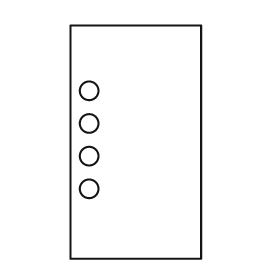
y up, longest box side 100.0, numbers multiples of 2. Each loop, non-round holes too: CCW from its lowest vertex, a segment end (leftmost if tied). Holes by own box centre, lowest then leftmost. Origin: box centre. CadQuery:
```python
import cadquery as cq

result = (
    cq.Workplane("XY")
    .moveTo(-28.0, -50.0)
    .lineTo(28.0, -50.0)
    .lineTo(28.0, 50.0)
    .lineTo(-28.0, 50.0)
    .close()
    .moveTo(-20.0, -20.0)
    .circle(4.0)
    .moveTo(-20.0, -6.0)
    .circle(4.0)
    .moveTo(-20.0, 8.0)
    .circle(4.0)
    .moveTo(-20.0, 22.0)
    .circle(4.0)
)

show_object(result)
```